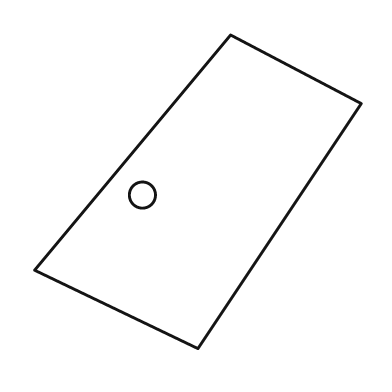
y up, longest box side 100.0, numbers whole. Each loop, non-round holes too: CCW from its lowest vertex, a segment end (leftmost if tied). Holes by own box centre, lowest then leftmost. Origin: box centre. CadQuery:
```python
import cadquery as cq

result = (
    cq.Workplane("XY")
    .moveTo(0.0, -48.0)
    .lineTo(50.0, 27.0)
    .lineTo(10.0, 48.0)
    .lineTo(-50.0, -24.0)
    .close()
    .moveTo(-17.0, -1.0)
    .circle(4.0)
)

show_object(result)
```